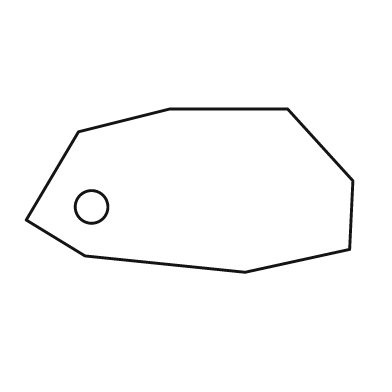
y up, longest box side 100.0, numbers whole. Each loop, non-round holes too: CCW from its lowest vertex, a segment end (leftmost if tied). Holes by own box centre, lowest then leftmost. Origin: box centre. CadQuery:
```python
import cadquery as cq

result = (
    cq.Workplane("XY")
    .moveTo(17.0, -25.0)
    .lineTo(49.0, -18.0)
    .lineTo(50.0, 3.0)
    .lineTo(30.0, 25.0)
    .lineTo(-6.0, 25.0)
    .lineTo(-34.0, 18.0)
    .lineTo(-50.0, -9.0)
    .lineTo(-32.0, -20.0)
    .close()
    .moveTo(-30.0, -5.0)
    .circle(5.0)
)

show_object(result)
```